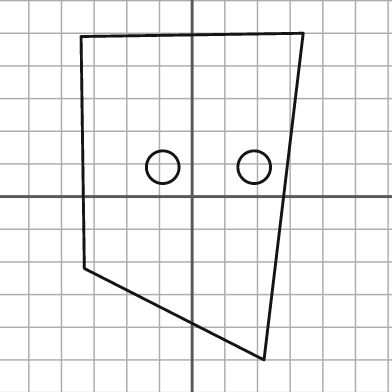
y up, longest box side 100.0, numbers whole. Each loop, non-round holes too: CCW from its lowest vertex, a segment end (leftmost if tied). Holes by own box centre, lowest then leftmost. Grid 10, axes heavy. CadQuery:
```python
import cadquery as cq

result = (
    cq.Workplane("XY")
    .moveTo(22.0, -50.0)
    .lineTo(34.0, 50.0)
    .lineTo(-34.0, 49.0)
    .lineTo(-33.0, -22.0)
    .close()
    .moveTo(-9.0, 9.0)
    .circle(5.0)
    .moveTo(19.0, 9.0)
    .circle(5.0)
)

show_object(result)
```